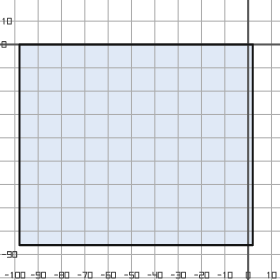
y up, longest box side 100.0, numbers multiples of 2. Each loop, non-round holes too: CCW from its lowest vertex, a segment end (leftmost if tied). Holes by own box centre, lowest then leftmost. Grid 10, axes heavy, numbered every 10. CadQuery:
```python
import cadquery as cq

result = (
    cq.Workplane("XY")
    .moveTo(-98.0, -86.0)
    .lineTo(2.0, -86.0)
    .lineTo(2.0, 0.0)
    .lineTo(-98.0, 0.0)
    .close()
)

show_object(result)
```